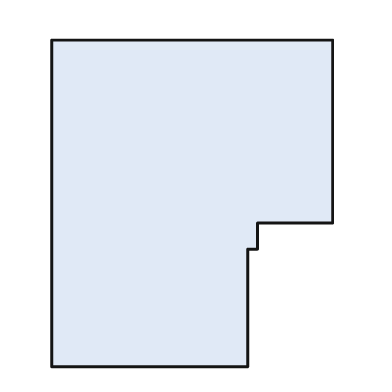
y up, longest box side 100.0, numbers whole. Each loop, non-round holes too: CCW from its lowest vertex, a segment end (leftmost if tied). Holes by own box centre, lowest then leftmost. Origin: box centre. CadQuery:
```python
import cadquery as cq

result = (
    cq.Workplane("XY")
    .moveTo(-43.0, -50.0)
    .lineTo(17.0, -50.0)
    .lineTo(17.0, -14.0)
    .lineTo(20.0, -14.0)
    .lineTo(20.0, -6.0)
    .lineTo(43.0, -6.0)
    .lineTo(43.0, 50.0)
    .lineTo(-43.0, 50.0)
    .close()
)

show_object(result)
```